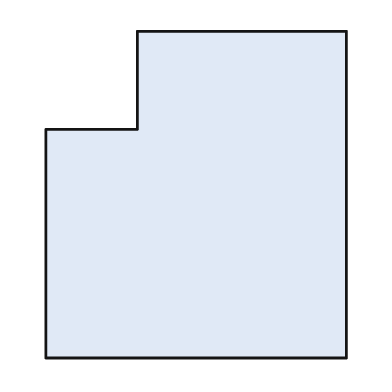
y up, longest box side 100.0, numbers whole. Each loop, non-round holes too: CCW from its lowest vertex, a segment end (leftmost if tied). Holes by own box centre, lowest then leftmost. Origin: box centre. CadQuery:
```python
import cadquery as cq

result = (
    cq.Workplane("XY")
    .moveTo(-46.0, -50.0)
    .lineTo(46.0, -50.0)
    .lineTo(46.0, 50.0)
    .lineTo(-18.0, 50.0)
    .lineTo(-18.0, 20.0)
    .lineTo(-46.0, 20.0)
    .close()
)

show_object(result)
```